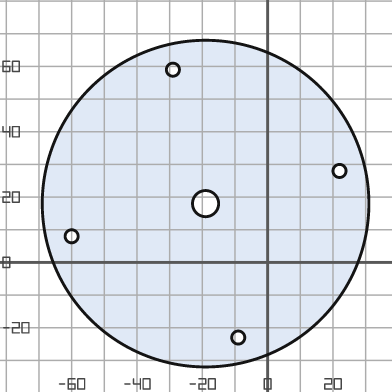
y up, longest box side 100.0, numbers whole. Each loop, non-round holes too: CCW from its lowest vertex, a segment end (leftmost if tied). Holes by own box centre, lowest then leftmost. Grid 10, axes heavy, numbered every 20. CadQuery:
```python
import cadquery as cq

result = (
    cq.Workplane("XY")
    .moveTo(-19.0, 18.0)
    .circle(50.0)
    .moveTo(-9.0, -23.0)
    .circle(2.0)
    .moveTo(-60.0, 8.0)
    .circle(2.0)
    .moveTo(-19.0, 18.0)
    .circle(4.0)
    .moveTo(22.0, 28.0)
    .circle(2.0)
    .moveTo(-29.0, 59.0)
    .circle(2.0)
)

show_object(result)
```